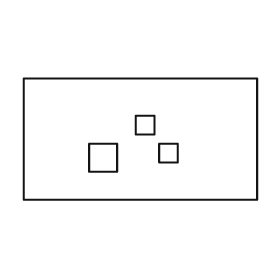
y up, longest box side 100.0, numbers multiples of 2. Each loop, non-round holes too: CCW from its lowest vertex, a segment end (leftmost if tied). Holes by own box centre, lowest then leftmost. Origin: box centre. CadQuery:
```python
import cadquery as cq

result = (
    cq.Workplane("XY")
    .moveTo(-50.0, -26.0)
    .lineTo(50.0, -26.0)
    .lineTo(50.0, 26.0)
    .lineTo(-50.0, 26.0)
    .close()
    .moveTo(-22.0, -14.0)
    .lineTo(-10.0, -14.0)
    .lineTo(-10.0, -2.0)
    .lineTo(-22.0, -2.0)
    .close()
    .moveTo(8.0, -10.0)
    .lineTo(16.0, -10.0)
    .lineTo(16.0, -2.0)
    .lineTo(8.0, -2.0)
    .close()
    .moveTo(-2.0, 2.0)
    .lineTo(6.0, 2.0)
    .lineTo(6.0, 10.0)
    .lineTo(-2.0, 10.0)
    .close()
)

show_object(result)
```